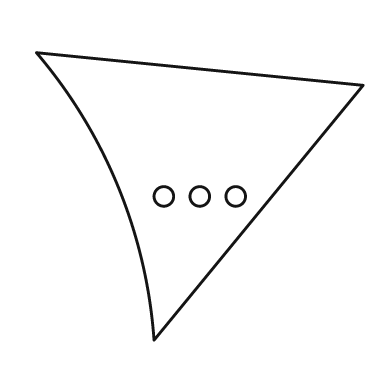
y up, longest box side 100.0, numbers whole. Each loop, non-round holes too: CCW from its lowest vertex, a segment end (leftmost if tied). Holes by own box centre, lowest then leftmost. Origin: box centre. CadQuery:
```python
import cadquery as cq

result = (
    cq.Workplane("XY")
    .moveTo(-14.0, -44.0)
    .lineTo(50.0, 34.0)
    .lineTo(-50.0, 44.0)
    .threePointArc((-25.0, 3.0), (-14.0, -44.0))
    .close()
    .moveTo(-11.0, 0.0)
    .circle(3.0)
    .moveTo(0.0, 0.0)
    .circle(3.0)
    .moveTo(11.0, 0.0)
    .circle(3.0)
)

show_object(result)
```